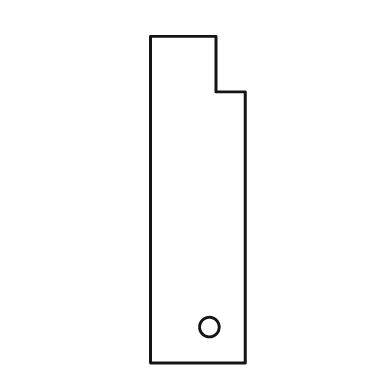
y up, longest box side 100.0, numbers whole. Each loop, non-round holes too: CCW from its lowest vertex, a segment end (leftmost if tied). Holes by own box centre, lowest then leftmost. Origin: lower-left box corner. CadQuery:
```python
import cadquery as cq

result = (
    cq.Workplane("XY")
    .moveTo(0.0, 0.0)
    .lineTo(29.0, 0.0)
    .lineTo(29.0, 83.0)
    .lineTo(20.0, 83.0)
    .lineTo(20.0, 100.0)
    .lineTo(0.0, 100.0)
    .close()
    .moveTo(18.0, 11.0)
    .circle(3.0)
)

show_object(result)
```